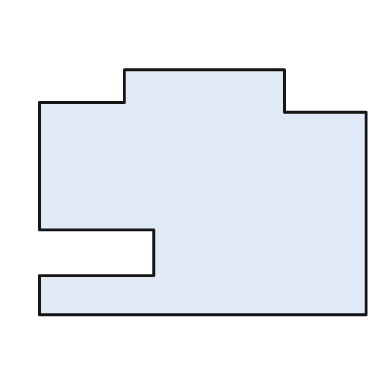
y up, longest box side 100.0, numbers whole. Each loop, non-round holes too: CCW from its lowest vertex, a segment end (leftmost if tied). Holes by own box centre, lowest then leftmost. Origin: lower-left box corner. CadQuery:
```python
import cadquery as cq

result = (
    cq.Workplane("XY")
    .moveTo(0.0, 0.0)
    .lineTo(100.0, 0.0)
    .lineTo(100.0, 62.0)
    .lineTo(75.0, 62.0)
    .lineTo(75.0, 75.0)
    .lineTo(26.0, 75.0)
    .lineTo(26.0, 65.0)
    .lineTo(0.0, 65.0)
    .lineTo(0.0, 26.0)
    .lineTo(35.0, 26.0)
    .lineTo(35.0, 12.0)
    .lineTo(0.0, 12.0)
    .close()
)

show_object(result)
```